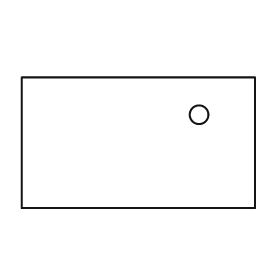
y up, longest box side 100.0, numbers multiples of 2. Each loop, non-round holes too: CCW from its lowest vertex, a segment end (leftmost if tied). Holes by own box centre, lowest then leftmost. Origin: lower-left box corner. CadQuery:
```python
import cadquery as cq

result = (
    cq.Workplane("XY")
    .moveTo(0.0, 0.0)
    .lineTo(100.0, 0.0)
    .lineTo(100.0, 56.0)
    .lineTo(0.0, 56.0)
    .close()
    .moveTo(76.0, 40.0)
    .circle(4.0)
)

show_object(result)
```